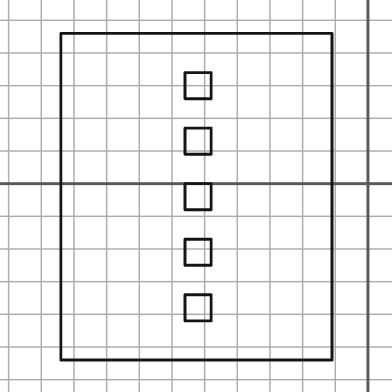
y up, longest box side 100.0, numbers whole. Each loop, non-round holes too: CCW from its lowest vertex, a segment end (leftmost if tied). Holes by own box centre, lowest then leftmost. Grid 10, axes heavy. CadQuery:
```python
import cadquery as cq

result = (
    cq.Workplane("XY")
    .moveTo(-94.0, -54.0)
    .lineTo(-11.0, -54.0)
    .lineTo(-11.0, 46.0)
    .lineTo(-94.0, 46.0)
    .close()
    .moveTo(-56.0, -42.0)
    .lineTo(-48.0, -42.0)
    .lineTo(-48.0, -34.0)
    .lineTo(-56.0, -34.0)
    .close()
    .moveTo(-56.0, -25.0)
    .lineTo(-48.0, -25.0)
    .lineTo(-48.0, -17.0)
    .lineTo(-56.0, -17.0)
    .close()
    .moveTo(-56.0, -8.0)
    .lineTo(-48.0, -8.0)
    .lineTo(-48.0, 0.0)
    .lineTo(-56.0, 0.0)
    .close()
    .moveTo(-56.0, 9.0)
    .lineTo(-48.0, 9.0)
    .lineTo(-48.0, 17.0)
    .lineTo(-56.0, 17.0)
    .close()
    .moveTo(-56.0, 26.0)
    .lineTo(-48.0, 26.0)
    .lineTo(-48.0, 34.0)
    .lineTo(-56.0, 34.0)
    .close()
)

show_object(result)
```